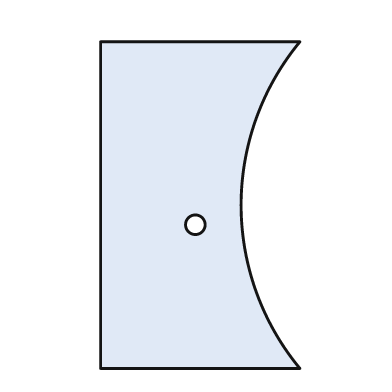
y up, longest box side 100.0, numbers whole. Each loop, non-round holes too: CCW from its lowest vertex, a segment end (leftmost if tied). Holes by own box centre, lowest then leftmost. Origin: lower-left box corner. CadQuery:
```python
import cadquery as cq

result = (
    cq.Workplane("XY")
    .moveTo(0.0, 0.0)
    .lineTo(61.0, 0.0)
    .threePointArc((43.0, 50.0), (61.0, 100.0))
    .lineTo(0.0, 100.0)
    .close()
    .moveTo(29.0, 44.0)
    .circle(3.0)
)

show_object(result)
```